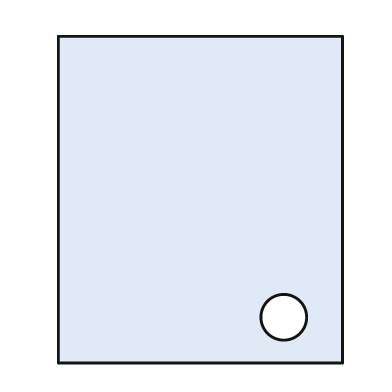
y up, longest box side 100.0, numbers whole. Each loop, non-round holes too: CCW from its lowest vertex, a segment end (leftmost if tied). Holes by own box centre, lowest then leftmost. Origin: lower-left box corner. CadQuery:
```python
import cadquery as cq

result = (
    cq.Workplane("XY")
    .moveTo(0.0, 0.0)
    .lineTo(87.0, 0.0)
    .lineTo(87.0, 100.0)
    .lineTo(0.0, 100.0)
    .close()
    .moveTo(69.0, 14.0)
    .circle(7.0)
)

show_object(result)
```